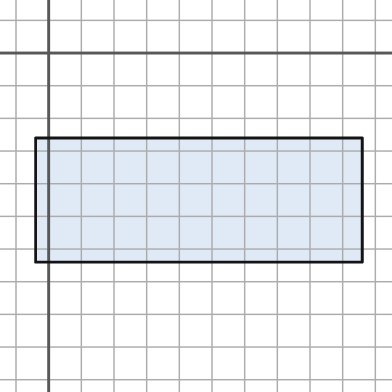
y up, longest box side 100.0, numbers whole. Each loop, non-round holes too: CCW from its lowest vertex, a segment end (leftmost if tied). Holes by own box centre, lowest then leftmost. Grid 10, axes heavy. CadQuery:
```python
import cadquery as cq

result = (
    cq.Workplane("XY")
    .moveTo(-4.0, -64.0)
    .lineTo(96.0, -64.0)
    .lineTo(96.0, -26.0)
    .lineTo(-4.0, -26.0)
    .close()
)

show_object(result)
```